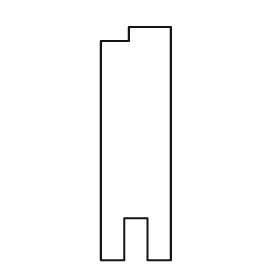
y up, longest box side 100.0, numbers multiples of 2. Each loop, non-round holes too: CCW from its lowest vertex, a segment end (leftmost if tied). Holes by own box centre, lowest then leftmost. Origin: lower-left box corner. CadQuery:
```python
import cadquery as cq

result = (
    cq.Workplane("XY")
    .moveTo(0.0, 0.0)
    .lineTo(10.0, 0.0)
    .lineTo(10.0, 18.0)
    .lineTo(20.0, 18.0)
    .lineTo(20.0, 0.0)
    .lineTo(30.0, 0.0)
    .lineTo(30.0, 100.0)
    .lineTo(12.0, 100.0)
    .lineTo(12.0, 94.0)
    .lineTo(0.0, 94.0)
    .close()
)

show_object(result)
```